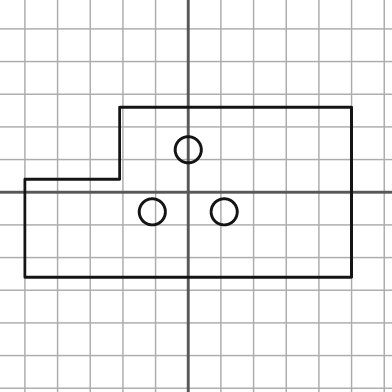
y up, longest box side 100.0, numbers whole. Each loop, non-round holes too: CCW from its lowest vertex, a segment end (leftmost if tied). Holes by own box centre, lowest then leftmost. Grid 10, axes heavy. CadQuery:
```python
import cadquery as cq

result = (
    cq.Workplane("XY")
    .moveTo(-50.0, -26.0)
    .lineTo(50.0, -26.0)
    .lineTo(50.0, 26.0)
    .lineTo(-21.0, 26.0)
    .lineTo(-21.0, 4.0)
    .lineTo(-50.0, 4.0)
    .close()
    .moveTo(-11.0, -6.0)
    .circle(4.0)
    .moveTo(11.0, -6.0)
    .circle(4.0)
    .moveTo(0.0, 13.0)
    .circle(4.0)
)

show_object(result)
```